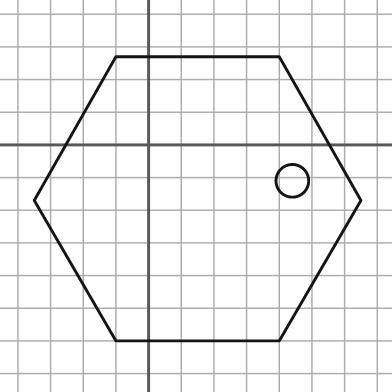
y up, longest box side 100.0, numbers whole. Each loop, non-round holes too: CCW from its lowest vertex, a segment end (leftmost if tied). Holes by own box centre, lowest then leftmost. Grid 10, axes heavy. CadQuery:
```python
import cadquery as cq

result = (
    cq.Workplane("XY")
    .moveTo(-10.0, -60.0)
    .lineTo(40.0, -60.0)
    .lineTo(65.0, -17.0)
    .lineTo(40.0, 27.0)
    .lineTo(-10.0, 27.0)
    .lineTo(-35.0, -17.0)
    .close()
    .moveTo(44.0, -11.0)
    .circle(5.0)
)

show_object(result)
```